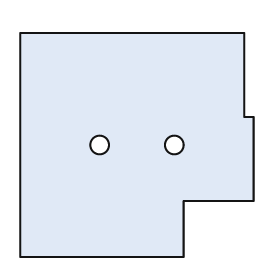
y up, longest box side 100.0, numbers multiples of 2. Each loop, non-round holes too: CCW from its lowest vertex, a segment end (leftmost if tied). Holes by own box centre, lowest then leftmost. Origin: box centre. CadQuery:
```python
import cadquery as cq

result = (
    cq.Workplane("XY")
    .moveTo(-50.0, -48.0)
    .lineTo(20.0, -48.0)
    .lineTo(20.0, -24.0)
    .lineTo(50.0, -24.0)
    .lineTo(50.0, 12.0)
    .lineTo(46.0, 12.0)
    .lineTo(46.0, 48.0)
    .lineTo(-50.0, 48.0)
    .close()
    .moveTo(-16.0, 0.0)
    .circle(4.0)
    .moveTo(16.0, 0.0)
    .circle(4.0)
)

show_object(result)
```